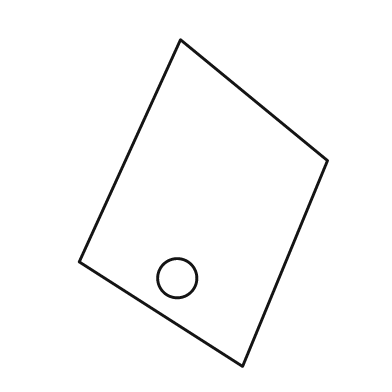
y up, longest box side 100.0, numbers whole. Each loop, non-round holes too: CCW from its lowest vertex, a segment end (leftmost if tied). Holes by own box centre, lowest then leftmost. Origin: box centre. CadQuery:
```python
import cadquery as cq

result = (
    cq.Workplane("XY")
    .moveTo(12.0, -50.0)
    .lineTo(38.0, 13.0)
    .lineTo(-7.0, 50.0)
    .lineTo(-38.0, -18.0)
    .close()
    .moveTo(-8.0, -23.0)
    .circle(6.0)
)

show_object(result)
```